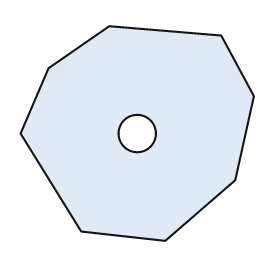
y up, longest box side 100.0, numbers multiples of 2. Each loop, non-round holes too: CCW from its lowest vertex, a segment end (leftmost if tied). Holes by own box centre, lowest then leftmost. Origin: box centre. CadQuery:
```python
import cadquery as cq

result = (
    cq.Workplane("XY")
    .moveTo(12.0, -46.0)
    .lineTo(42.0, -20.0)
    .lineTo(50.0, 16.0)
    .lineTo(36.0, 42.0)
    .lineTo(-12.0, 46.0)
    .lineTo(-38.0, 28.0)
    .lineTo(-50.0, 0.0)
    .lineTo(-24.0, -42.0)
    .close()
    .moveTo(0.0, 0.0)
    .circle(8.0)
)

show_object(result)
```